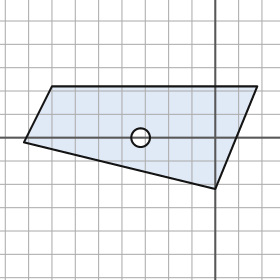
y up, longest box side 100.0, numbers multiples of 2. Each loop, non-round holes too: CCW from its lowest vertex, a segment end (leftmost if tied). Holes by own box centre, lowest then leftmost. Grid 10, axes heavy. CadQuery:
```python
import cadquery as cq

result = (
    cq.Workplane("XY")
    .moveTo(0.0, -22.0)
    .lineTo(18.0, 22.0)
    .lineTo(-70.0, 22.0)
    .lineTo(-82.0, -2.0)
    .close()
    .moveTo(-32.0, 0.0)
    .circle(4.0)
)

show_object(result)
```